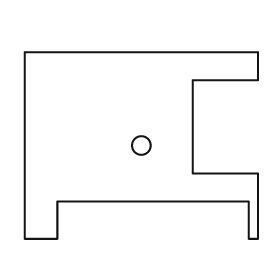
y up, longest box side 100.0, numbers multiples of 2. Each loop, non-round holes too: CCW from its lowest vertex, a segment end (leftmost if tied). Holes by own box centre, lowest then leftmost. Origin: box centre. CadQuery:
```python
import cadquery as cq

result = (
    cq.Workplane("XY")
    .moveTo(-50.0, -40.0)
    .lineTo(-36.0, -40.0)
    .lineTo(-36.0, -24.0)
    .lineTo(46.0, -24.0)
    .lineTo(46.0, -40.0)
    .lineTo(50.0, -40.0)
    .lineTo(50.0, -12.0)
    .lineTo(22.0, -12.0)
    .lineTo(22.0, 28.0)
    .lineTo(50.0, 28.0)
    .lineTo(50.0, 40.0)
    .lineTo(-50.0, 40.0)
    .close()
    .moveTo(0.0, 0.0)
    .circle(4.0)
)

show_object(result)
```